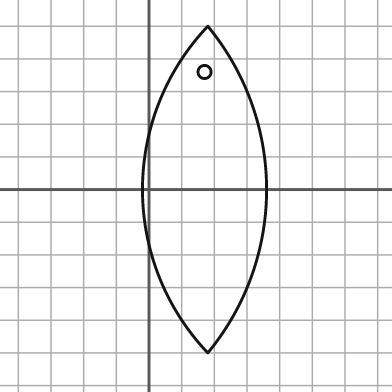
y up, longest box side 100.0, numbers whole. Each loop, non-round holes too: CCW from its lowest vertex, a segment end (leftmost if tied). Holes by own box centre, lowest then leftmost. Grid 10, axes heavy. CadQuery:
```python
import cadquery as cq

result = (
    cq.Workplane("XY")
    .moveTo(18.0, -50.0)
    .threePointArc((36.0, 0.0), (18.0, 50.0))
    .threePointArc((-2.0, 0.0), (18.0, -50.0))
    .close()
    .moveTo(17.0, 36.0)
    .circle(2.0)
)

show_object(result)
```